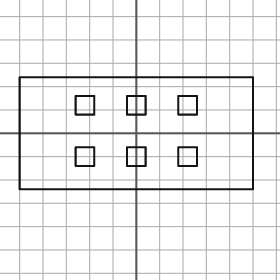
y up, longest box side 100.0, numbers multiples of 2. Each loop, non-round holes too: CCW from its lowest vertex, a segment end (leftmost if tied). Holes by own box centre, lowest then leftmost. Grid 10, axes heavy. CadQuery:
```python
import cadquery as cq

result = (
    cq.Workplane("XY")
    .moveTo(-50.0, -24.0)
    .lineTo(50.0, -24.0)
    .lineTo(50.0, 24.0)
    .lineTo(-50.0, 24.0)
    .close()
    .moveTo(-26.0, -14.0)
    .lineTo(-18.0, -14.0)
    .lineTo(-18.0, -6.0)
    .lineTo(-26.0, -6.0)
    .close()
    .moveTo(-4.0, -14.0)
    .lineTo(4.0, -14.0)
    .lineTo(4.0, -6.0)
    .lineTo(-4.0, -6.0)
    .close()
    .moveTo(18.0, -14.0)
    .lineTo(26.0, -14.0)
    .lineTo(26.0, -6.0)
    .lineTo(18.0, -6.0)
    .close()
    .moveTo(-26.0, 8.0)
    .lineTo(-18.0, 8.0)
    .lineTo(-18.0, 16.0)
    .lineTo(-26.0, 16.0)
    .close()
    .moveTo(-4.0, 8.0)
    .lineTo(4.0, 8.0)
    .lineTo(4.0, 16.0)
    .lineTo(-4.0, 16.0)
    .close()
    .moveTo(18.0, 8.0)
    .lineTo(26.0, 8.0)
    .lineTo(26.0, 16.0)
    .lineTo(18.0, 16.0)
    .close()
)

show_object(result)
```